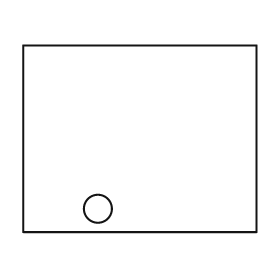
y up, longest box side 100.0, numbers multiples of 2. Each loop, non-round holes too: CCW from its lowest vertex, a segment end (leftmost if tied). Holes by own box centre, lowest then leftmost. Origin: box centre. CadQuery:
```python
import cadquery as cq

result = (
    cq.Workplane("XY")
    .moveTo(-50.0, -40.0)
    .lineTo(50.0, -40.0)
    .lineTo(50.0, 40.0)
    .lineTo(-50.0, 40.0)
    .close()
    .moveTo(-18.0, -30.0)
    .circle(6.0)
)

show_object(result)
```